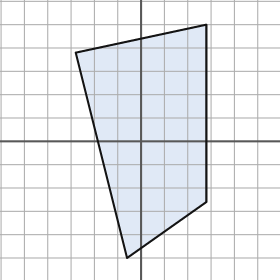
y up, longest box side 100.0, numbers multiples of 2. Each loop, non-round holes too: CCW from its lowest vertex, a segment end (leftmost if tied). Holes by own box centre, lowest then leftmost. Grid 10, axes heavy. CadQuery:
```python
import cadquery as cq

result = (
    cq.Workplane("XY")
    .moveTo(-6.0, -50.0)
    .lineTo(28.0, -26.0)
    .lineTo(28.0, 50.0)
    .lineTo(-28.0, 38.0)
    .close()
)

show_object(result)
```